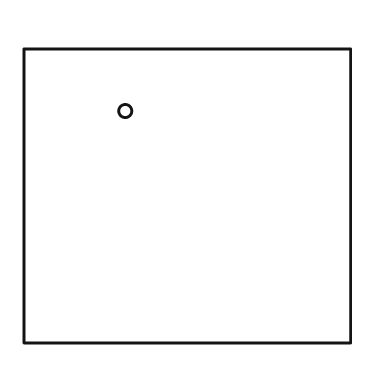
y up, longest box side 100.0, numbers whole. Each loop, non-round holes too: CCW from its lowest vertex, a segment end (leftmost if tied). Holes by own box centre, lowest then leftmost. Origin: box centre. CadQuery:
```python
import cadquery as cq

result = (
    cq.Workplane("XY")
    .moveTo(-50.0, -45.0)
    .lineTo(50.0, -45.0)
    .lineTo(50.0, 45.0)
    .lineTo(-50.0, 45.0)
    .close()
    .moveTo(-19.0, 26.0)
    .circle(2.0)
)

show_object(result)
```